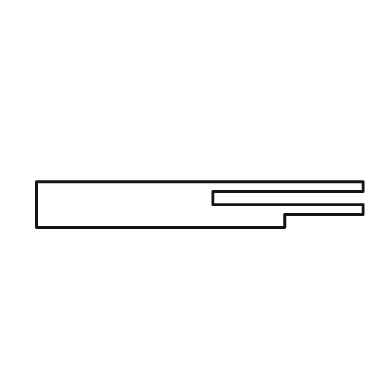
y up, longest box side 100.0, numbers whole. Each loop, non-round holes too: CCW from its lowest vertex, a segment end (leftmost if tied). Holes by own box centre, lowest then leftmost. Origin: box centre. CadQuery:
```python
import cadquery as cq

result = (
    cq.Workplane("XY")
    .moveTo(-50.0, -7.0)
    .lineTo(26.0, -7.0)
    .lineTo(26.0, -3.0)
    .lineTo(50.0, -3.0)
    .lineTo(50.0, 0.0)
    .lineTo(4.0, 0.0)
    .lineTo(4.0, 4.0)
    .lineTo(50.0, 4.0)
    .lineTo(50.0, 7.0)
    .lineTo(-50.0, 7.0)
    .close()
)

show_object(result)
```